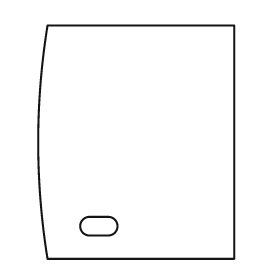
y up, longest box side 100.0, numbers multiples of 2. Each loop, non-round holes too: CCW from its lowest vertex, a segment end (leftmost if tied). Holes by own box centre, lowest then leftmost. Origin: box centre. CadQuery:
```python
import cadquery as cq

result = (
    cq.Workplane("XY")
    .moveTo(-38.0, -50.0)
    .lineTo(42.0, -50.0)
    .lineTo(42.0, 50.0)
    .lineTo(-38.0, 50.0)
    .threePointArc((-42.0, 0.0), (-38.0, -50.0))
    .close()
    .moveTo(-20.0, -40.0)
    .lineTo(-12.0, -40.0)
    .threePointArc((-8.0, -36.0), (-12.0, -32.0))
    .lineTo(-20.0, -32.0)
    .threePointArc((-24.0, -36.0), (-20.0, -40.0))
    .close()
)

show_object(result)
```